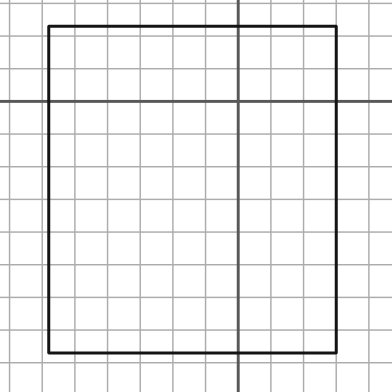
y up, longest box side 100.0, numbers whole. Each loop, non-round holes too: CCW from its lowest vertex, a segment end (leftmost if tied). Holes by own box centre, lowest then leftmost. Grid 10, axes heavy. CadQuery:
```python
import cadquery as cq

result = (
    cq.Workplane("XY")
    .moveTo(-58.0, -77.0)
    .lineTo(30.0, -77.0)
    .lineTo(30.0, 23.0)
    .lineTo(-58.0, 23.0)
    .close()
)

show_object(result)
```